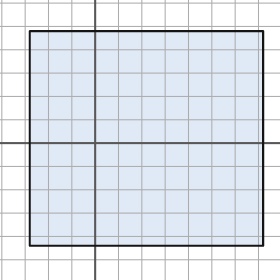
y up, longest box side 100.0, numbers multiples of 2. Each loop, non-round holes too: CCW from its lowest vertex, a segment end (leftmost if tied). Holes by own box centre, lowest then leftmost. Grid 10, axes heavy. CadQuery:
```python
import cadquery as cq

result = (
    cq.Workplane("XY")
    .moveTo(-28.0, -44.0)
    .lineTo(72.0, -44.0)
    .lineTo(72.0, 48.0)
    .lineTo(-28.0, 48.0)
    .close()
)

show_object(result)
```